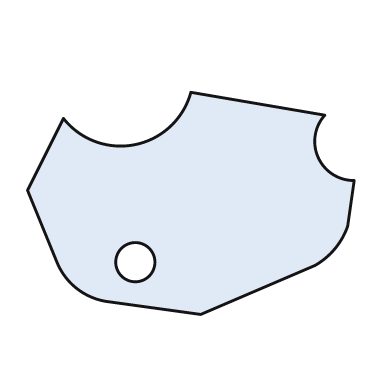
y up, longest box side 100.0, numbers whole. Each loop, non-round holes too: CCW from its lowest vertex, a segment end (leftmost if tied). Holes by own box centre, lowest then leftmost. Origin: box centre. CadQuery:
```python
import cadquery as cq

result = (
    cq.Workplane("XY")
    .moveTo(3.0, -34.0)
    .lineTo(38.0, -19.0)
    .threePointArc((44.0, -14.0), (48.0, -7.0))
    .lineTo(50.0, 7.0)
    .threePointArc((39.0, 14.0), (41.0, 27.0))
    .lineTo(0.0, 34.0)
    .threePointArc((-17.0, 18.0), (-39.0, 26.0))
    .lineTo(-50.0, 4.0)
    .lineTo(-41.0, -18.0)
    .threePointArc((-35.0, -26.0), (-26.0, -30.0))
    .close()
    .moveTo(-17.0, -18.0)
    .circle(6.0)
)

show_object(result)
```